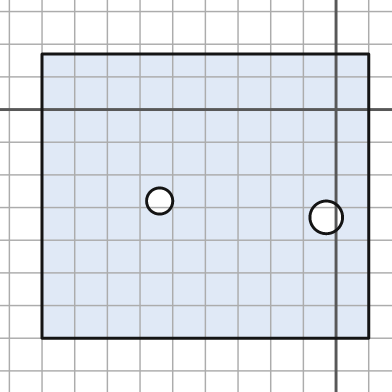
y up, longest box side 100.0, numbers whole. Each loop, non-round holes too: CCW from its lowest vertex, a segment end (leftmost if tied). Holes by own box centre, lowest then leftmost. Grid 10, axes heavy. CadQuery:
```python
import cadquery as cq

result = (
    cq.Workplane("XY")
    .moveTo(-90.0, -70.0)
    .lineTo(10.0, -70.0)
    .lineTo(10.0, 17.0)
    .lineTo(-90.0, 17.0)
    .close()
    .moveTo(-3.0, -33.0)
    .circle(5.0)
    .moveTo(-54.0, -28.0)
    .circle(4.0)
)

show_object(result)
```